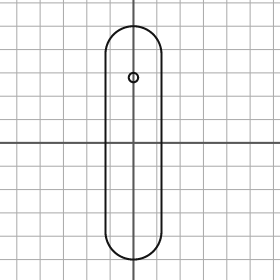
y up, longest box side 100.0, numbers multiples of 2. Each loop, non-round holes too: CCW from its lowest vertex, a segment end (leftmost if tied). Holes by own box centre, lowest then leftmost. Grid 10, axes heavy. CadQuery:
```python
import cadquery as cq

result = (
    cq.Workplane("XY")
    .moveTo(-12.0, -38.0)
    .threePointArc((0.0, -50.0), (12.0, -38.0))
    .lineTo(12.0, 38.0)
    .threePointArc((0.0, 50.0), (-12.0, 38.0))
    .close()
    .moveTo(0.0, 28.0)
    .circle(2.0)
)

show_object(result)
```